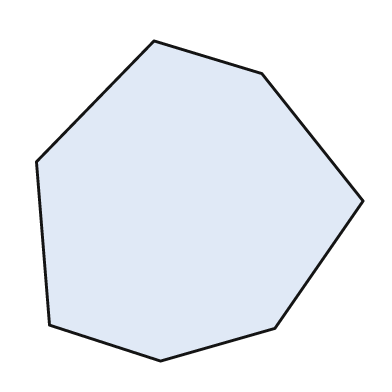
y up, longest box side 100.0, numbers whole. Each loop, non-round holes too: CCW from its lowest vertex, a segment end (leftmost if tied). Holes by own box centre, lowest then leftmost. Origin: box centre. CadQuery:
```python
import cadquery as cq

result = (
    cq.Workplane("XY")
    .moveTo(-12.0, -49.0)
    .lineTo(23.0, -39.0)
    .lineTo(50.0, 0.0)
    .lineTo(19.0, 39.0)
    .lineTo(-14.0, 49.0)
    .lineTo(-50.0, 12.0)
    .lineTo(-46.0, -38.0)
    .close()
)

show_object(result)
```